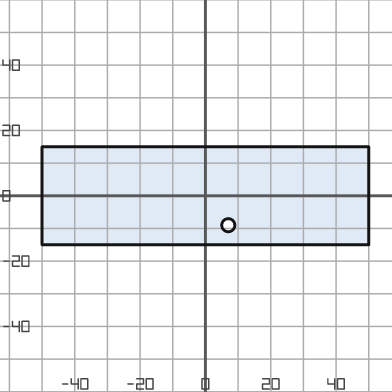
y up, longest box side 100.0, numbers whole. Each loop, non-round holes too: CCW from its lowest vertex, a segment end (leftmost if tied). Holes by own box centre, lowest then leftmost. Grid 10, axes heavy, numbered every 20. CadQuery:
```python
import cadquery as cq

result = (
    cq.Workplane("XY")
    .moveTo(-50.0, -15.0)
    .lineTo(50.0, -15.0)
    .lineTo(50.0, 15.0)
    .lineTo(-50.0, 15.0)
    .close()
    .moveTo(7.0, -9.0)
    .circle(2.0)
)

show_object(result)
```